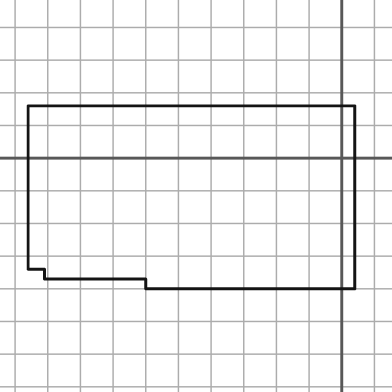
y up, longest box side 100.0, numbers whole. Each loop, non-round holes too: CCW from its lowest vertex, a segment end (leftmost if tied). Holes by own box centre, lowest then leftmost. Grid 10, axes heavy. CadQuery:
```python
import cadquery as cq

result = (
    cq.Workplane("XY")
    .moveTo(-60.0, -40.0)
    .lineTo(4.0, -40.0)
    .lineTo(4.0, 16.0)
    .lineTo(-96.0, 16.0)
    .lineTo(-96.0, -34.0)
    .lineTo(-91.0, -34.0)
    .lineTo(-91.0, -37.0)
    .lineTo(-60.0, -37.0)
    .close()
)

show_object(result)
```